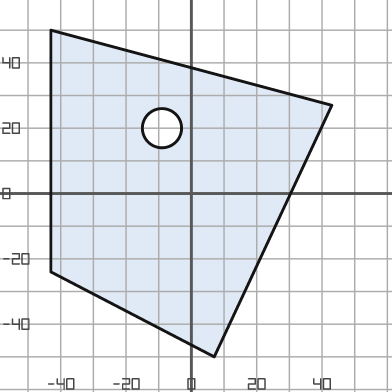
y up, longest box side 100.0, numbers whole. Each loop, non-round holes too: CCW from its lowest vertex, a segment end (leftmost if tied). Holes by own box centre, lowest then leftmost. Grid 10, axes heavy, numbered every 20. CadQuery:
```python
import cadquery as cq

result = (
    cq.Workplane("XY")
    .moveTo(7.0, -50.0)
    .lineTo(43.0, 27.0)
    .lineTo(-43.0, 50.0)
    .lineTo(-43.0, -24.0)
    .close()
    .moveTo(-9.0, 20.0)
    .circle(6.0)
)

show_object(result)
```